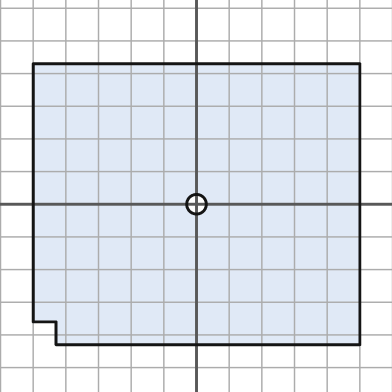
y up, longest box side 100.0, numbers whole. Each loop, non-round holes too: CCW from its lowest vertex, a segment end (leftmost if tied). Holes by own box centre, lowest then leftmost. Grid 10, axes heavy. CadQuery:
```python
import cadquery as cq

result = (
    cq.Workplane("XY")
    .moveTo(-43.0, -43.0)
    .lineTo(50.0, -43.0)
    .lineTo(50.0, 43.0)
    .lineTo(-50.0, 43.0)
    .lineTo(-50.0, -36.0)
    .lineTo(-43.0, -36.0)
    .close()
    .moveTo(0.0, 0.0)
    .circle(3.0)
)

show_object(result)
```